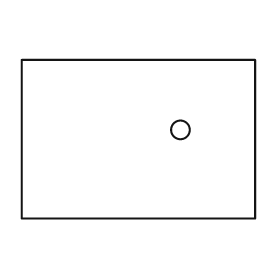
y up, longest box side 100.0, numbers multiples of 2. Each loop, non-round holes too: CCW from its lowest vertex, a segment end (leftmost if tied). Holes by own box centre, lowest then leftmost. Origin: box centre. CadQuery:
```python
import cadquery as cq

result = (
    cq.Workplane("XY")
    .moveTo(-50.0, -34.0)
    .lineTo(50.0, -34.0)
    .lineTo(50.0, 34.0)
    .lineTo(-50.0, 34.0)
    .close()
    .moveTo(18.0, 4.0)
    .circle(4.0)
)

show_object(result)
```